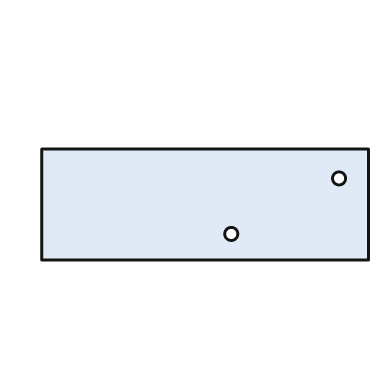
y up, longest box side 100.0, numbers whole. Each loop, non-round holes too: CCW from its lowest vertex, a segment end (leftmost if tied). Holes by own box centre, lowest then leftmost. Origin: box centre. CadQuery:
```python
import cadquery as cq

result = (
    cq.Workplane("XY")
    .moveTo(-50.0, -17.0)
    .lineTo(50.0, -17.0)
    .lineTo(50.0, 17.0)
    .lineTo(-50.0, 17.0)
    .close()
    .moveTo(8.0, -9.0)
    .circle(2.0)
    .moveTo(41.0, 8.0)
    .circle(2.0)
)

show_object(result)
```